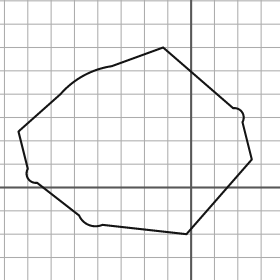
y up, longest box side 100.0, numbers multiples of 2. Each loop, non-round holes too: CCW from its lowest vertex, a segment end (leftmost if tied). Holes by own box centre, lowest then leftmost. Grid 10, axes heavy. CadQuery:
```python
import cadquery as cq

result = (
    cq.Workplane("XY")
    .moveTo(-2.0, -20.0)
    .lineTo(26.0, 12.0)
    .lineTo(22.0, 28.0)
    .threePointArc((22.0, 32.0), (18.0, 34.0))
    .lineTo(-12.0, 60.0)
    .lineTo(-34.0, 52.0)
    .threePointArc((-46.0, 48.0), (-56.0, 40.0))
    .lineTo(-74.0, 24.0)
    .lineTo(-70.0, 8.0)
    .threePointArc((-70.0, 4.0), (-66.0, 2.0))
    .lineTo(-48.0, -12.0)
    .threePointArc((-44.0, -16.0), (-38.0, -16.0))
    .close()
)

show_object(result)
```